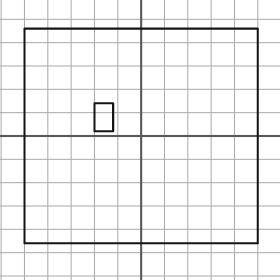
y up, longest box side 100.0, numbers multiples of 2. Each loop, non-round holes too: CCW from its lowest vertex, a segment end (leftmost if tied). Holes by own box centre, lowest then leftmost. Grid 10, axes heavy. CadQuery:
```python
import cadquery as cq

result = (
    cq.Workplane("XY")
    .moveTo(-50.0, -46.0)
    .lineTo(50.0, -46.0)
    .lineTo(50.0, 46.0)
    .lineTo(-50.0, 46.0)
    .close()
    .moveTo(-20.0, 2.0)
    .lineTo(-12.0, 2.0)
    .lineTo(-12.0, 14.0)
    .lineTo(-20.0, 14.0)
    .close()
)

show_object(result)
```